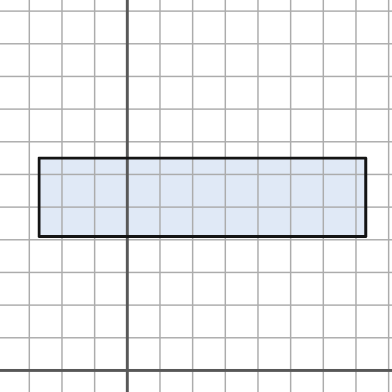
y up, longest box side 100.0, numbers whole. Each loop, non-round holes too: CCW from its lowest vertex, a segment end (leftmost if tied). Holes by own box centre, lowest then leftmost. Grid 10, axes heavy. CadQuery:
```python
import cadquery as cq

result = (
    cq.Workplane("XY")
    .moveTo(-27.0, 41.0)
    .lineTo(73.0, 41.0)
    .lineTo(73.0, 65.0)
    .lineTo(-27.0, 65.0)
    .close()
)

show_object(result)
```